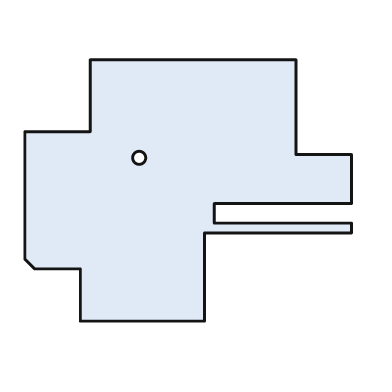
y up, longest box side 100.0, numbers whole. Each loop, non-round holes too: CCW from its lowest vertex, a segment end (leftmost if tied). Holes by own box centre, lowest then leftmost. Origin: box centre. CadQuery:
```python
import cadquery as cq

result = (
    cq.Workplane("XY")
    .moveTo(-33.0, -40.0)
    .lineTo(5.0, -40.0)
    .lineTo(5.0, -13.0)
    .lineTo(50.0, -13.0)
    .lineTo(50.0, -10.0)
    .lineTo(8.0, -10.0)
    .lineTo(8.0, -4.0)
    .lineTo(50.0, -4.0)
    .lineTo(50.0, 11.0)
    .lineTo(33.0, 11.0)
    .lineTo(33.0, 40.0)
    .lineTo(-30.0, 40.0)
    .lineTo(-30.0, 18.0)
    .lineTo(-50.0, 18.0)
    .lineTo(-50.0, -21.0)
    .lineTo(-47.0, -24.0)
    .lineTo(-33.0, -24.0)
    .close()
    .moveTo(-15.0, 10.0)
    .circle(2.0)
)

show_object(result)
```